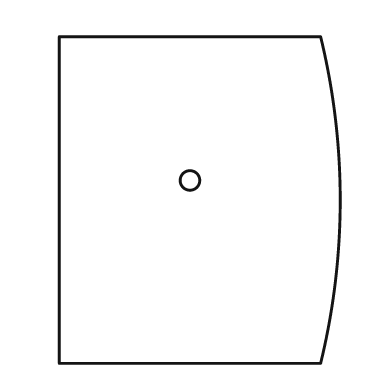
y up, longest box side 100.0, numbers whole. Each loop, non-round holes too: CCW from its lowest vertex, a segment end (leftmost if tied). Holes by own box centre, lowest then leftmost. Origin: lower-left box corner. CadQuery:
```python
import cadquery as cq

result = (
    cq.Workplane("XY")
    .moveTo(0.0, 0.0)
    .lineTo(80.0, 0.0)
    .threePointArc((86.0, 50.0), (80.0, 100.0))
    .lineTo(0.0, 100.0)
    .close()
    .moveTo(40.0, 56.0)
    .circle(3.0)
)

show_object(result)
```